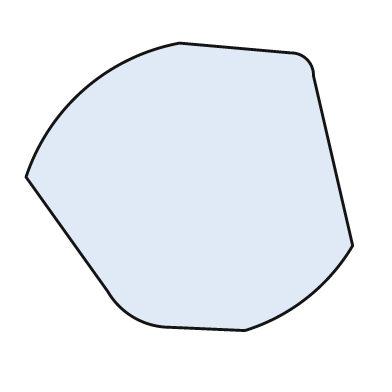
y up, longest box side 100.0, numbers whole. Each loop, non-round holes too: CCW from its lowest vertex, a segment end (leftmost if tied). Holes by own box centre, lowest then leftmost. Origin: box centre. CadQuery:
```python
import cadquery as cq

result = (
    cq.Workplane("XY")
    .moveTo(17.0, -44.0)
    .threePointArc((36.0, -34.0), (50.0, -18.0))
    .lineTo(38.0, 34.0)
    .threePointArc((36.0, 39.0), (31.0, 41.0))
    .lineTo(-3.0, 44.0)
    .threePointArc((-32.0, 30.0), (-50.0, 3.0))
    .lineTo(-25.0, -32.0)
    .threePointArc((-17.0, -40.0), (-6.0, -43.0))
    .close()
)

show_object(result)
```